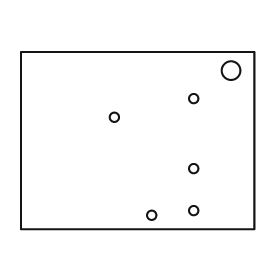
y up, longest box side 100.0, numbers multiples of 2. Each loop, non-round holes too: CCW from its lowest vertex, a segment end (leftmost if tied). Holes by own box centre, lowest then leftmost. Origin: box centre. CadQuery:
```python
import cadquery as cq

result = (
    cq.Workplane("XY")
    .moveTo(-50.0, -38.0)
    .lineTo(50.0, -38.0)
    .lineTo(50.0, 38.0)
    .lineTo(-50.0, 38.0)
    .close()
    .moveTo(6.0, -32.0)
    .circle(2.0)
    .moveTo(24.0, -30.0)
    .circle(2.0)
    .moveTo(24.0, -12.0)
    .circle(2.0)
    .moveTo(-10.0, 10.0)
    .circle(2.0)
    .moveTo(24.0, 18.0)
    .circle(2.0)
    .moveTo(40.0, 30.0)
    .circle(4.0)
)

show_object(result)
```